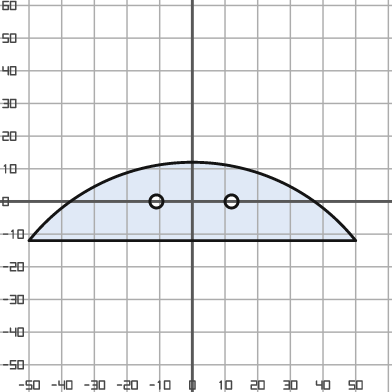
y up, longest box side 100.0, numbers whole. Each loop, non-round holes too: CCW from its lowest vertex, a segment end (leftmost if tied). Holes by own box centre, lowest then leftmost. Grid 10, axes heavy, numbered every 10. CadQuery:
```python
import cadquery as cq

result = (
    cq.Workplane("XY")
    .moveTo(-50.0, -12.0)
    .lineTo(50.0, -12.0)
    .threePointArc((0.0, 12.0), (-50.0, -12.0))
    .close()
    .moveTo(-11.0, 0.0)
    .circle(2.0)
    .moveTo(12.0, 0.0)
    .circle(2.0)
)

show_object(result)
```